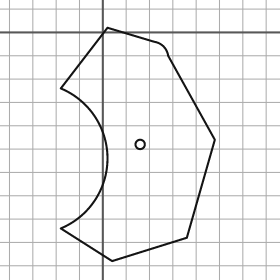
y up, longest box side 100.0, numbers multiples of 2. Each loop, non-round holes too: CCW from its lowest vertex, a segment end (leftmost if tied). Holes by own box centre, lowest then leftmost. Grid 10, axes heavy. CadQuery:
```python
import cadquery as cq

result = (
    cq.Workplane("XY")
    .moveTo(4.0, -98.0)
    .lineTo(36.0, -88.0)
    .lineTo(48.0, -46.0)
    .lineTo(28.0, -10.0)
    .threePointArc((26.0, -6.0), (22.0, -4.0))
    .lineTo(2.0, 2.0)
    .lineTo(-18.0, -24.0)
    .threePointArc((2.0, -54.0), (-18.0, -84.0))
    .close()
    .moveTo(16.0, -48.0)
    .circle(2.0)
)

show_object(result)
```